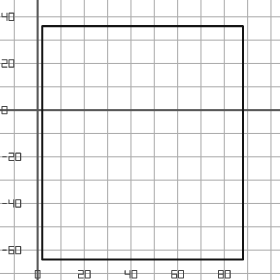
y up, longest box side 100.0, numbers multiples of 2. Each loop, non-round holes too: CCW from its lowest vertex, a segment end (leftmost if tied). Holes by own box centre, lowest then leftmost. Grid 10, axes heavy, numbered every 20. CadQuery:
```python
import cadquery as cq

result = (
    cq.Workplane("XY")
    .moveTo(2.0, -64.0)
    .lineTo(88.0, -64.0)
    .lineTo(88.0, 36.0)
    .lineTo(2.0, 36.0)
    .close()
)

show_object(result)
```